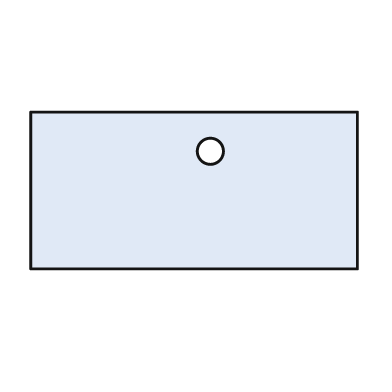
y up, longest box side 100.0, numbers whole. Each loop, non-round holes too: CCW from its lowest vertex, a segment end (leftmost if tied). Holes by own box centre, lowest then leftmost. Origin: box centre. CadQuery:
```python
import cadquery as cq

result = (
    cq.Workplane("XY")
    .moveTo(-50.0, -24.0)
    .lineTo(50.0, -24.0)
    .lineTo(50.0, 24.0)
    .lineTo(-50.0, 24.0)
    .close()
    .moveTo(5.0, 12.0)
    .circle(4.0)
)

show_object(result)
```